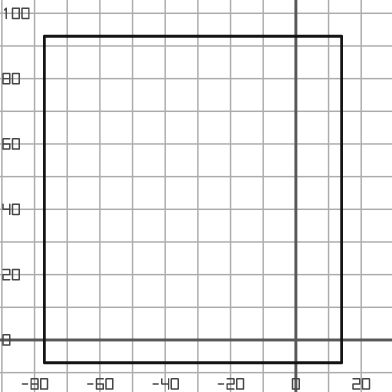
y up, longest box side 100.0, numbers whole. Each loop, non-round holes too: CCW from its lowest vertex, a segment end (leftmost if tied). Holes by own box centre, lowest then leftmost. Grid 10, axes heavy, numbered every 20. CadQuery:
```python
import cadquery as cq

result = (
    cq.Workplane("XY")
    .moveTo(-77.0, -7.0)
    .lineTo(14.0, -7.0)
    .lineTo(14.0, 93.0)
    .lineTo(-77.0, 93.0)
    .close()
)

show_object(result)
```